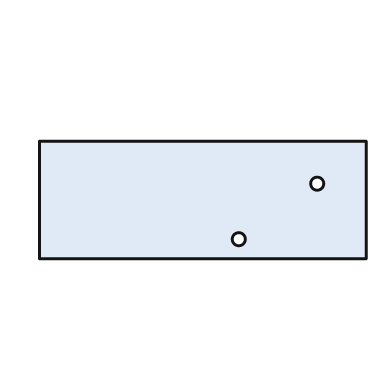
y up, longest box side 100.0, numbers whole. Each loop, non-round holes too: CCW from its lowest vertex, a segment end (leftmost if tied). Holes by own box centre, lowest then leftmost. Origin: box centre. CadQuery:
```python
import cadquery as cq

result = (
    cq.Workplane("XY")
    .moveTo(-50.0, -18.0)
    .lineTo(50.0, -18.0)
    .lineTo(50.0, 18.0)
    .lineTo(-50.0, 18.0)
    .close()
    .moveTo(11.0, -12.0)
    .circle(2.0)
    .moveTo(35.0, 5.0)
    .circle(2.0)
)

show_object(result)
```